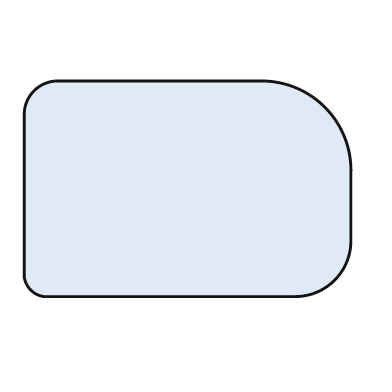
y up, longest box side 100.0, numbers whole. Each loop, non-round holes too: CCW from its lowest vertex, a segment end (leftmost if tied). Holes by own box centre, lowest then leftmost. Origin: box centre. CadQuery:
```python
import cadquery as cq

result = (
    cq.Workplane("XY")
    .moveTo(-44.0, -33.0)
    .lineTo(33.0, -33.0)
    .threePointArc((45.0, -28.0), (50.0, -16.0))
    .lineTo(50.0, 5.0)
    .threePointArc((42.0, 25.0), (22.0, 33.0))
    .lineTo(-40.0, 33.0)
    .threePointArc((-47.0, 30.0), (-50.0, 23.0))
    .lineTo(-50.0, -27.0)
    .threePointArc((-48.0, -31.0), (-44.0, -33.0))
    .close()
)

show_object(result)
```